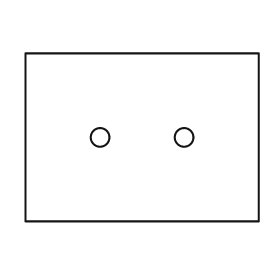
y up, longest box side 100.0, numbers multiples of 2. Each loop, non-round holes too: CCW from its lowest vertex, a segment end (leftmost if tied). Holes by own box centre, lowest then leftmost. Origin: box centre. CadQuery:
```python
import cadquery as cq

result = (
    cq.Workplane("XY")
    .moveTo(-50.0, -36.0)
    .lineTo(50.0, -36.0)
    .lineTo(50.0, 36.0)
    .lineTo(-50.0, 36.0)
    .close()
    .moveTo(-18.0, 0.0)
    .circle(4.0)
    .moveTo(18.0, 0.0)
    .circle(4.0)
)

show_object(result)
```